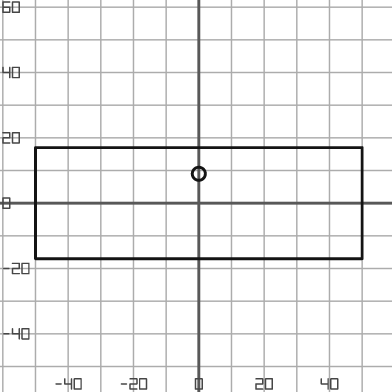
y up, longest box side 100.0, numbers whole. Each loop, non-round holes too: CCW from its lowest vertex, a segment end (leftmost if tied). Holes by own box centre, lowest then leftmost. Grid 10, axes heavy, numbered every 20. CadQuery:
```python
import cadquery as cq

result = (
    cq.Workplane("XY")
    .moveTo(-50.0, -17.0)
    .lineTo(50.0, -17.0)
    .lineTo(50.0, 17.0)
    .lineTo(-50.0, 17.0)
    .close()
    .moveTo(0.0, 9.0)
    .circle(2.0)
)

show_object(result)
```